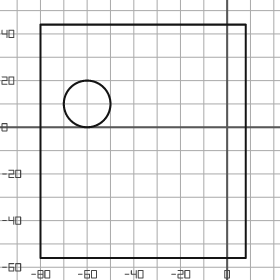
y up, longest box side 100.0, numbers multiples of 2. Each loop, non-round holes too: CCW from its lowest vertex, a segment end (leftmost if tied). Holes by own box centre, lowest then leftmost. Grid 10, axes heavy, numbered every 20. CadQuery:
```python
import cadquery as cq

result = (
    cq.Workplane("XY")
    .moveTo(-80.0, -56.0)
    .lineTo(8.0, -56.0)
    .lineTo(8.0, 44.0)
    .lineTo(-80.0, 44.0)
    .close()
    .moveTo(-60.0, 10.0)
    .circle(10.0)
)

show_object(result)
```